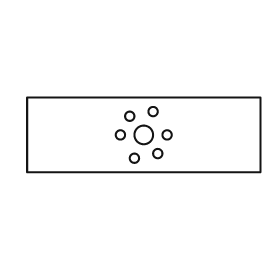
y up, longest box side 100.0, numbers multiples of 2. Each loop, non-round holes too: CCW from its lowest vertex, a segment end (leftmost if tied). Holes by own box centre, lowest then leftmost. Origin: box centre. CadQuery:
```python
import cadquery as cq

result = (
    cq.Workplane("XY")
    .moveTo(-50.0, -16.0)
    .lineTo(50.0, -16.0)
    .lineTo(50.0, 16.0)
    .lineTo(-50.0, 16.0)
    .close()
    .moveTo(-4.0, -10.0)
    .circle(2.0)
    .moveTo(6.0, -8.0)
    .circle(2.0)
    .moveTo(-10.0, 0.0)
    .circle(2.0)
    .moveTo(0.0, 0.0)
    .circle(4.0)
    .moveTo(10.0, 0.0)
    .circle(2.0)
    .moveTo(-6.0, 8.0)
    .circle(2.0)
    .moveTo(4.0, 10.0)
    .circle(2.0)
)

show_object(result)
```